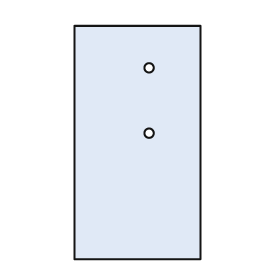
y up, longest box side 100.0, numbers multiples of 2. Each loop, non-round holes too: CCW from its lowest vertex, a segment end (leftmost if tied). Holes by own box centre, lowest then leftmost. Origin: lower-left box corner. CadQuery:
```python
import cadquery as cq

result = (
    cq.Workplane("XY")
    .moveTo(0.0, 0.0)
    .lineTo(54.0, 0.0)
    .lineTo(54.0, 100.0)
    .lineTo(0.0, 100.0)
    .close()
    .moveTo(32.0, 54.0)
    .circle(2.0)
    .moveTo(32.0, 82.0)
    .circle(2.0)
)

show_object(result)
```